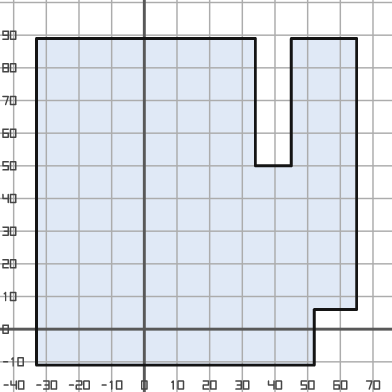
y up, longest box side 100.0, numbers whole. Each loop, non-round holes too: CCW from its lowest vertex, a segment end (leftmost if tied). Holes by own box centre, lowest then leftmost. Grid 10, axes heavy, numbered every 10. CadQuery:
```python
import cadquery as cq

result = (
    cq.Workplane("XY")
    .moveTo(-33.0, -11.0)
    .lineTo(52.0, -11.0)
    .lineTo(52.0, 6.0)
    .lineTo(65.0, 6.0)
    .lineTo(65.0, 89.0)
    .lineTo(45.0, 89.0)
    .lineTo(45.0, 50.0)
    .lineTo(34.0, 50.0)
    .lineTo(34.0, 89.0)
    .lineTo(-33.0, 89.0)
    .close()
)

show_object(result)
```